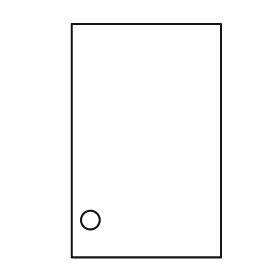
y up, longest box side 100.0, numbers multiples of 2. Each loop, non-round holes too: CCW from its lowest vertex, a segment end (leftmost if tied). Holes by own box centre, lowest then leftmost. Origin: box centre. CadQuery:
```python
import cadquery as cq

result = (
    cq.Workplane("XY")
    .moveTo(-32.0, -50.0)
    .lineTo(32.0, -50.0)
    .lineTo(32.0, 50.0)
    .lineTo(-32.0, 50.0)
    .close()
    .moveTo(-24.0, -34.0)
    .circle(4.0)
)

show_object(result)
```